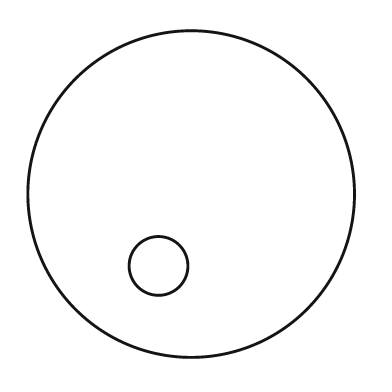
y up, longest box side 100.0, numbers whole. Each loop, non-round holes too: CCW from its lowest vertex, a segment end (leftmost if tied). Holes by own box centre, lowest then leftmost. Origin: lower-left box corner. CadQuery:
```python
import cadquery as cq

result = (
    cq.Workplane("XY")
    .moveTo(50.0, 50.0)
    .circle(50.0)
    .moveTo(40.0, 28.0)
    .circle(9.0)
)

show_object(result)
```